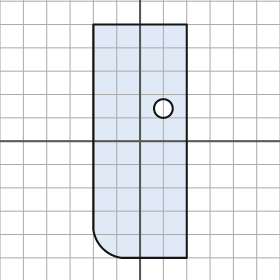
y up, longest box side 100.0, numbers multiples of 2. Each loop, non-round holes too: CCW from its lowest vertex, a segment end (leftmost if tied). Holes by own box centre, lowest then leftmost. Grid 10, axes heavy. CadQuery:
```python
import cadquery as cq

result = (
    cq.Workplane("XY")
    .moveTo(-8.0, -50.0)
    .lineTo(20.0, -50.0)
    .lineTo(20.0, 50.0)
    .lineTo(-20.0, 50.0)
    .lineTo(-20.0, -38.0)
    .threePointArc((-16.0, -46.0), (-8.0, -50.0))
    .close()
    .moveTo(10.0, 14.0)
    .circle(4.0)
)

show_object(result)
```